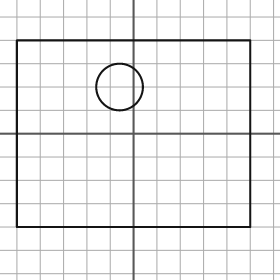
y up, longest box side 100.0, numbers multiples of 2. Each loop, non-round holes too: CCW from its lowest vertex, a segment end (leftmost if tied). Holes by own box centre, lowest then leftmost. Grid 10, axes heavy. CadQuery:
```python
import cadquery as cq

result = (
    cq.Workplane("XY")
    .moveTo(-50.0, -40.0)
    .lineTo(50.0, -40.0)
    .lineTo(50.0, 40.0)
    .lineTo(-50.0, 40.0)
    .close()
    .moveTo(-6.0, 20.0)
    .circle(10.0)
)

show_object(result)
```